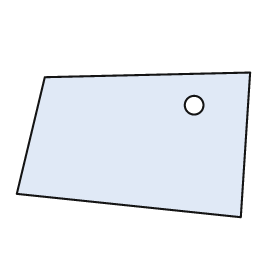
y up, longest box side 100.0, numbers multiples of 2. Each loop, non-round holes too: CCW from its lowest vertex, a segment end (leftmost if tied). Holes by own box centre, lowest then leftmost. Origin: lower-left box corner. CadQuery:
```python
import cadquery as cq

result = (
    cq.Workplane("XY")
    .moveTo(96.0, 0.0)
    .lineTo(100.0, 62.0)
    .lineTo(12.0, 60.0)
    .lineTo(0.0, 10.0)
    .close()
    .moveTo(76.0, 48.0)
    .circle(4.0)
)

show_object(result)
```